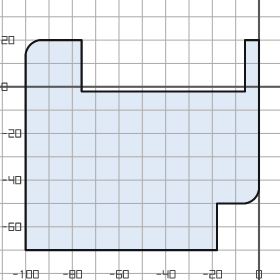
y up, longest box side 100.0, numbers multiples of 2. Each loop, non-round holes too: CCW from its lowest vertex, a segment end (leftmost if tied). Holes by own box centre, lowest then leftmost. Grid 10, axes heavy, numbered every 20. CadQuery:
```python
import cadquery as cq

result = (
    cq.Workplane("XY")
    .moveTo(-100.0, -70.0)
    .lineTo(-18.0, -70.0)
    .lineTo(-18.0, -50.0)
    .lineTo(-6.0, -50.0)
    .threePointArc((-2.0, -48.0), (0.0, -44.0))
    .lineTo(0.0, 20.0)
    .lineTo(-6.0, 20.0)
    .lineTo(-6.0, -2.0)
    .lineTo(-76.0, -2.0)
    .lineTo(-76.0, 20.0)
    .lineTo(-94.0, 20.0)
    .threePointArc((-98.0, 18.0), (-100.0, 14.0))
    .close()
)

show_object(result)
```